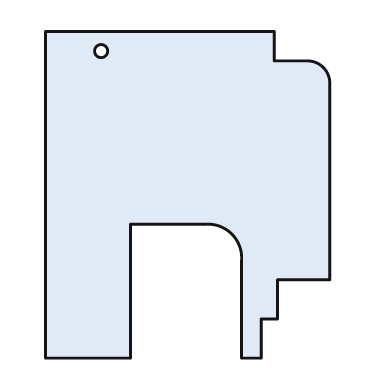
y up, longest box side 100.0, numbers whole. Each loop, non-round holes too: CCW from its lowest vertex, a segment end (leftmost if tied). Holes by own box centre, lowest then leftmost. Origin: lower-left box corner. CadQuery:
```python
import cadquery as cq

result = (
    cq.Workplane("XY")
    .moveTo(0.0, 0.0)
    .lineTo(26.0, 0.0)
    .lineTo(26.0, 41.0)
    .lineTo(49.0, 41.0)
    .threePointArc((57.0, 38.0), (60.0, 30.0))
    .lineTo(60.0, 0.0)
    .lineTo(66.0, 0.0)
    .lineTo(66.0, 12.0)
    .lineTo(71.0, 12.0)
    .lineTo(71.0, 24.0)
    .lineTo(87.0, 24.0)
    .lineTo(87.0, 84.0)
    .threePointArc((85.0, 89.0), (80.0, 91.0))
    .lineTo(70.0, 91.0)
    .lineTo(70.0, 100.0)
    .lineTo(0.0, 100.0)
    .close()
    .moveTo(17.0, 94.0)
    .circle(2.0)
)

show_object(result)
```